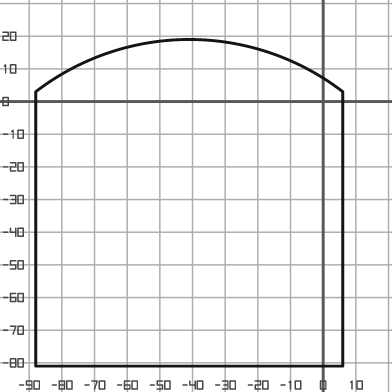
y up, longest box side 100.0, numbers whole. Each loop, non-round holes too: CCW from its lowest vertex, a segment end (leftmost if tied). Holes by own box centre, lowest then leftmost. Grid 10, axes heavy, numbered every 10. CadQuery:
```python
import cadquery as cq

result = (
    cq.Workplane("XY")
    .moveTo(-88.0, -81.0)
    .lineTo(6.0, -81.0)
    .lineTo(6.0, 3.0)
    .threePointArc((-41.0, 19.0), (-88.0, 3.0))
    .close()
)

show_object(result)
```